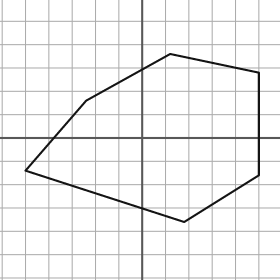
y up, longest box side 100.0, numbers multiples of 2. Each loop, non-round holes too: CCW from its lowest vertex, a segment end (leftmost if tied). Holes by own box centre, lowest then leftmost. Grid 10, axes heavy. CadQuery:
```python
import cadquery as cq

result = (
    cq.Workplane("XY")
    .moveTo(18.0, -36.0)
    .lineTo(50.0, -16.0)
    .lineTo(50.0, 28.0)
    .lineTo(12.0, 36.0)
    .lineTo(-24.0, 16.0)
    .lineTo(-50.0, -14.0)
    .close()
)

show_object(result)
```